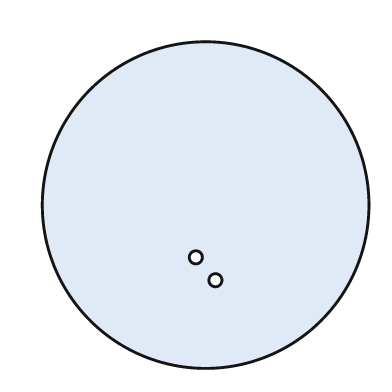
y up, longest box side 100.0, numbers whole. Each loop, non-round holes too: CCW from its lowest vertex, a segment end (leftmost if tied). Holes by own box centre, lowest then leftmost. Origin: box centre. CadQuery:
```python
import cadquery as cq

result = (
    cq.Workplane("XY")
    .moveTo(0.0, 0.0)
    .circle(50.0)
    .moveTo(3.0, -23.0)
    .circle(2.0)
    .moveTo(-3.0, -16.0)
    .circle(2.0)
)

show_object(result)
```